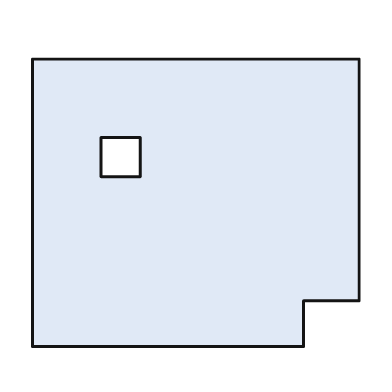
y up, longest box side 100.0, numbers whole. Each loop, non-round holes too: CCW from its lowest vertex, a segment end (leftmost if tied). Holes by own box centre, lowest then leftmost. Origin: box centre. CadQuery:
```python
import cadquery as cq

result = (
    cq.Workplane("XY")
    .moveTo(-50.0, -44.0)
    .lineTo(33.0, -44.0)
    .lineTo(33.0, -30.0)
    .lineTo(50.0, -30.0)
    .lineTo(50.0, 44.0)
    .lineTo(-50.0, 44.0)
    .close()
    .moveTo(-29.0, 8.0)
    .lineTo(-17.0, 8.0)
    .lineTo(-17.0, 20.0)
    .lineTo(-29.0, 20.0)
    .close()
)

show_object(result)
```